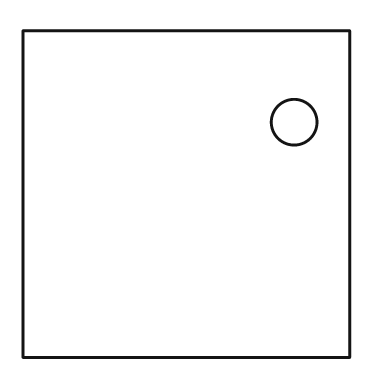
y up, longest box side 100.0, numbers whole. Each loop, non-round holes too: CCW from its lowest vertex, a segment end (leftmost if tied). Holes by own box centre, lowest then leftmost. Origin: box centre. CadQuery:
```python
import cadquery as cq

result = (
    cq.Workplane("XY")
    .moveTo(-50.0, -50.0)
    .lineTo(50.0, -50.0)
    .lineTo(50.0, 50.0)
    .lineTo(-50.0, 50.0)
    .close()
    .moveTo(33.0, 22.0)
    .circle(7.0)
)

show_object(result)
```